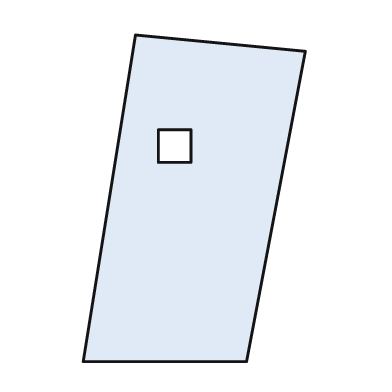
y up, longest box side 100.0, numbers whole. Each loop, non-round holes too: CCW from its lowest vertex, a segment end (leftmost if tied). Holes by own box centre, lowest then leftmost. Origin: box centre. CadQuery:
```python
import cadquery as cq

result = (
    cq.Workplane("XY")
    .moveTo(-34.0, -50.0)
    .lineTo(16.0, -50.0)
    .lineTo(34.0, 45.0)
    .lineTo(-18.0, 50.0)
    .close()
    .moveTo(-11.0, 11.0)
    .lineTo(-1.0, 11.0)
    .lineTo(-1.0, 21.0)
    .lineTo(-11.0, 21.0)
    .close()
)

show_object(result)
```